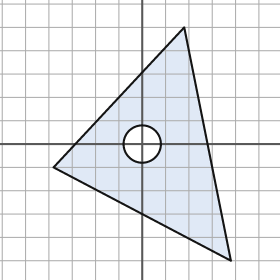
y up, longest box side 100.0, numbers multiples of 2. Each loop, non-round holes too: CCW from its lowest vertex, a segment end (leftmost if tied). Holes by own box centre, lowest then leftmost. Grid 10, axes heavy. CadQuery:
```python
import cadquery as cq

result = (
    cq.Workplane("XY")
    .moveTo(38.0, -50.0)
    .lineTo(18.0, 50.0)
    .lineTo(-38.0, -10.0)
    .close()
    .moveTo(0.0, 0.0)
    .circle(8.0)
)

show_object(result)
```